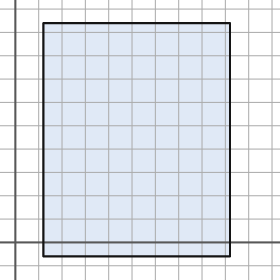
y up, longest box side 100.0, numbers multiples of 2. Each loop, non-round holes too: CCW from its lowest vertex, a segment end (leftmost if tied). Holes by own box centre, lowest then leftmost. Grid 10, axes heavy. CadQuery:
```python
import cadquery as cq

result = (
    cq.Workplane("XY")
    .moveTo(12.0, -6.0)
    .lineTo(92.0, -6.0)
    .lineTo(92.0, 94.0)
    .lineTo(12.0, 94.0)
    .close()
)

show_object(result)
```